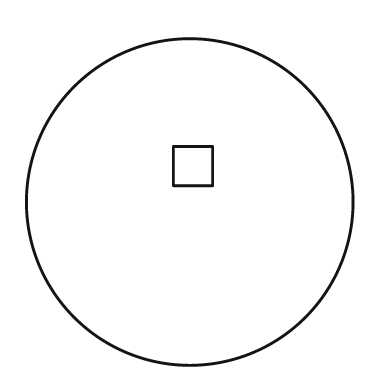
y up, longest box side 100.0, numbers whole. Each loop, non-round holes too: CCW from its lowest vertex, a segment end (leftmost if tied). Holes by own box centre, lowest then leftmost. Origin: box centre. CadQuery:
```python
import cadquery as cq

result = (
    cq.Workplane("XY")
    .moveTo(0.0, 0.0)
    .circle(50.0)
    .moveTo(-5.0, 5.0)
    .lineTo(7.0, 5.0)
    .lineTo(7.0, 17.0)
    .lineTo(-5.0, 17.0)
    .close()
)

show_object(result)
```